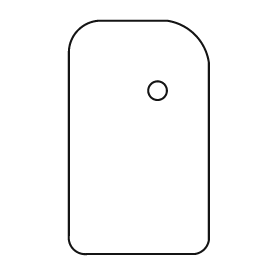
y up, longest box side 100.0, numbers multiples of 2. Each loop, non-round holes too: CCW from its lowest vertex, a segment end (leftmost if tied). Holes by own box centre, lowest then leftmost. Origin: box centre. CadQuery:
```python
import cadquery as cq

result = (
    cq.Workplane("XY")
    .moveTo(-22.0, -50.0)
    .lineTo(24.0, -50.0)
    .threePointArc((28.0, -48.0), (30.0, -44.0))
    .lineTo(30.0, 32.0)
    .threePointArc((24.0, 44.0), (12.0, 50.0))
    .lineTo(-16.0, 50.0)
    .threePointArc((-26.0, 46.0), (-30.0, 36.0))
    .lineTo(-30.0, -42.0)
    .threePointArc((-28.0, -48.0), (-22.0, -50.0))
    .close()
    .moveTo(8.0, 20.0)
    .circle(4.0)
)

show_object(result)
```